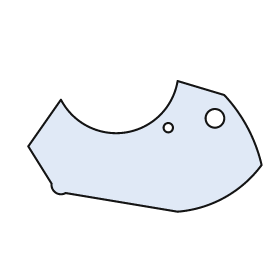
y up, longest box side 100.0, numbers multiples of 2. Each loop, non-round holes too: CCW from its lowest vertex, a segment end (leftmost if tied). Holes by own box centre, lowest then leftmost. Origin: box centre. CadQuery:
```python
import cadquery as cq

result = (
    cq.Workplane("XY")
    .moveTo(14.0, -28.0)
    .threePointArc((34.0, -22.0), (50.0, -8.0))
    .threePointArc((44.0, 8.0), (34.0, 22.0))
    .lineTo(14.0, 28.0)
    .threePointArc((-8.0, 6.0), (-36.0, 20.0))
    .lineTo(-50.0, 0.0)
    .lineTo(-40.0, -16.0)
    .threePointArc((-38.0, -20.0), (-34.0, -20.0))
    .close()
    .moveTo(10.0, 8.0)
    .circle(2.0)
    .moveTo(30.0, 12.0)
    .circle(4.0)
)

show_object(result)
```